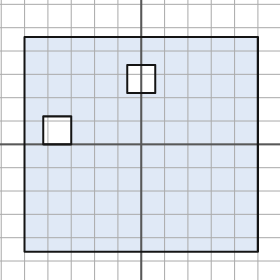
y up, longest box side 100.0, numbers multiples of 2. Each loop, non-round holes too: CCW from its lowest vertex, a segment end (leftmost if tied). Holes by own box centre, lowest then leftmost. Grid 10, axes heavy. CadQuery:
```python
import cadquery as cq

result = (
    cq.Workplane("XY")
    .moveTo(-50.0, -46.0)
    .lineTo(50.0, -46.0)
    .lineTo(50.0, 46.0)
    .lineTo(-50.0, 46.0)
    .close()
    .moveTo(-42.0, 0.0)
    .lineTo(-30.0, 0.0)
    .lineTo(-30.0, 12.0)
    .lineTo(-42.0, 12.0)
    .close()
    .moveTo(-6.0, 22.0)
    .lineTo(6.0, 22.0)
    .lineTo(6.0, 34.0)
    .lineTo(-6.0, 34.0)
    .close()
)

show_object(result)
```